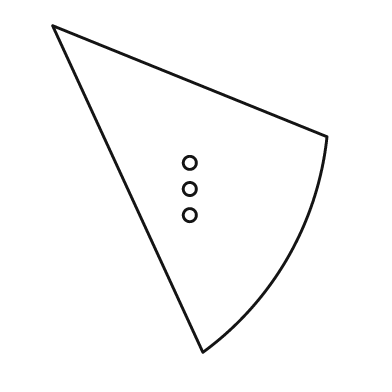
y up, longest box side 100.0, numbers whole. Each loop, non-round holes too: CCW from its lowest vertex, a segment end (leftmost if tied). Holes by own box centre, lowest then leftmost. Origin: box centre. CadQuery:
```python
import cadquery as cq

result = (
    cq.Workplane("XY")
    .moveTo(4.0, -50.0)
    .threePointArc((30.0, -21.0), (42.0, 16.0))
    .lineTo(-42.0, 50.0)
    .close()
    .moveTo(0.0, -8.0)
    .circle(2.0)
    .moveTo(0.0, 0.0)
    .circle(2.0)
    .moveTo(0.0, 8.0)
    .circle(2.0)
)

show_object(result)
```